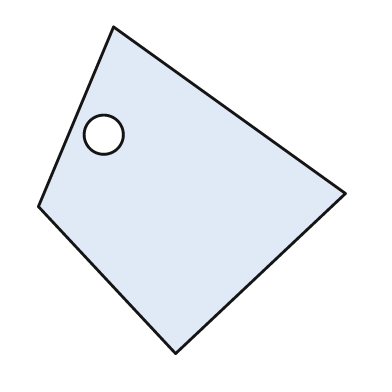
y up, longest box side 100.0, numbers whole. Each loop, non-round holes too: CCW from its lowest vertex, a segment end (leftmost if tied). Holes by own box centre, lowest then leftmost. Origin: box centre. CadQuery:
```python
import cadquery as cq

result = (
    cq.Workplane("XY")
    .moveTo(-5.0, -50.0)
    .lineTo(47.0, -1.0)
    .lineTo(-24.0, 50.0)
    .lineTo(-47.0, -5.0)
    .close()
    .moveTo(-27.0, 17.0)
    .circle(6.0)
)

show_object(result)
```